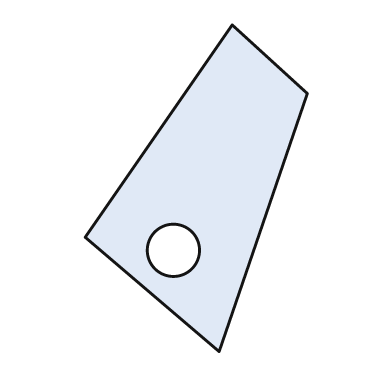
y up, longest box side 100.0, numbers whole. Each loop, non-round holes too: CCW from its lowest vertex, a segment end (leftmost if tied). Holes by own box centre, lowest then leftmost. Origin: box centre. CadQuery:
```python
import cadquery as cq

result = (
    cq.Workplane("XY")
    .moveTo(7.0, -50.0)
    .lineTo(34.0, 29.0)
    .lineTo(11.0, 50.0)
    .lineTo(-34.0, -15.0)
    .close()
    .moveTo(-7.0, -19.0)
    .circle(8.0)
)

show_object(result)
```